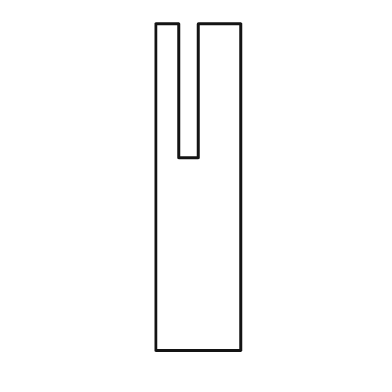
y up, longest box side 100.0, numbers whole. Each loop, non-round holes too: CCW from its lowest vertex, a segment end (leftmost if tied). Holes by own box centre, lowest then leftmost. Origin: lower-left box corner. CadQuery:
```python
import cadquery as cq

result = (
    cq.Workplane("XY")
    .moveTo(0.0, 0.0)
    .lineTo(26.0, 0.0)
    .lineTo(26.0, 100.0)
    .lineTo(13.0, 100.0)
    .lineTo(13.0, 59.0)
    .lineTo(7.0, 59.0)
    .lineTo(7.0, 100.0)
    .lineTo(0.0, 100.0)
    .close()
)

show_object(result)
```